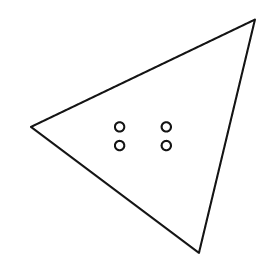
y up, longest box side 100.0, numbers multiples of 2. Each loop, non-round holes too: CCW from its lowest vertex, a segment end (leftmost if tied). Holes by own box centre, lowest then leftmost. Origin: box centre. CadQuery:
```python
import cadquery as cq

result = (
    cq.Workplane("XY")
    .moveTo(24.0, -50.0)
    .lineTo(48.0, 50.0)
    .lineTo(-48.0, 4.0)
    .close()
    .moveTo(-10.0, -4.0)
    .circle(2.0)
    .moveTo(10.0, -4.0)
    .circle(2.0)
    .moveTo(-10.0, 4.0)
    .circle(2.0)
    .moveTo(10.0, 4.0)
    .circle(2.0)
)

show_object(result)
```